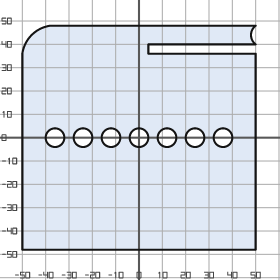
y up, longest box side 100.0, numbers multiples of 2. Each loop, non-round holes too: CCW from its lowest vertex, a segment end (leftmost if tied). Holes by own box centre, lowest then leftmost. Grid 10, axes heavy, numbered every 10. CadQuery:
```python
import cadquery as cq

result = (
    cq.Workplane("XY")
    .moveTo(-50.0, -48.0)
    .lineTo(50.0, -48.0)
    .lineTo(50.0, 36.0)
    .lineTo(4.0, 36.0)
    .lineTo(4.0, 40.0)
    .lineTo(50.0, 40.0)
    .threePointArc((48.0, 44.0), (50.0, 48.0))
    .lineTo(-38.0, 48.0)
    .threePointArc((-46.0, 44.0), (-50.0, 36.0))
    .close()
    .moveTo(-36.0, 0.0)
    .circle(4.0)
    .moveTo(-24.0, 0.0)
    .circle(4.0)
    .moveTo(-12.0, 0.0)
    .circle(4.0)
    .moveTo(0.0, 0.0)
    .circle(4.0)
    .moveTo(12.0, 0.0)
    .circle(4.0)
    .moveTo(24.0, 0.0)
    .circle(4.0)
    .moveTo(36.0, 0.0)
    .circle(4.0)
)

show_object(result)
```